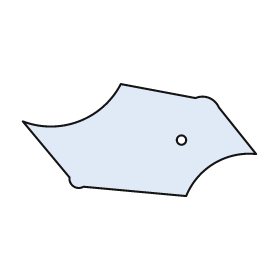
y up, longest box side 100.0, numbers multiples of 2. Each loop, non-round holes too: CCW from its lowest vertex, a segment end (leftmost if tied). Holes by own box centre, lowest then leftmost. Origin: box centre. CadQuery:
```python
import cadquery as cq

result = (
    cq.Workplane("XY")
    .moveTo(20.0, -24.0)
    .threePointArc((32.0, -10.0), (50.0, -6.0))
    .lineTo(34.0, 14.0)
    .threePointArc((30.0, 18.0), (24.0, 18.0))
    .lineTo(-8.0, 24.0)
    .threePointArc((-26.0, 8.0), (-50.0, 8.0))
    .lineTo(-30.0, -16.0)
    .threePointArc((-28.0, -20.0), (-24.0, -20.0))
    .close()
    .moveTo(18.0, 0.0)
    .circle(2.0)
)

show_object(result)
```